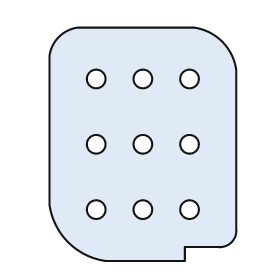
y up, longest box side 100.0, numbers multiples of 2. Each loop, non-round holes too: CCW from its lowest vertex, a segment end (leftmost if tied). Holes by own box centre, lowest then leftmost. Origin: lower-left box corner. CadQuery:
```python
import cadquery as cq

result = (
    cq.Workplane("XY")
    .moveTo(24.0, 0.0)
    .lineTo(58.0, 0.0)
    .lineTo(58.0, 6.0)
    .lineTo(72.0, 6.0)
    .threePointArc((78.0, 8.0), (80.0, 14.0))
    .lineTo(80.0, 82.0)
    .threePointArc((74.0, 94.0), (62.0, 100.0))
    .lineTo(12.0, 100.0)
    .threePointArc((4.0, 96.0), (0.0, 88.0))
    .lineTo(0.0, 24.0)
    .threePointArc((8.0, 8.0), (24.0, 0.0))
    .close()
    .moveTo(20.0, 22.0)
    .circle(4.0)
    .moveTo(40.0, 22.0)
    .circle(4.0)
    .moveTo(60.0, 22.0)
    .circle(4.0)
    .moveTo(20.0, 50.0)
    .circle(4.0)
    .moveTo(40.0, 50.0)
    .circle(4.0)
    .moveTo(60.0, 50.0)
    .circle(4.0)
    .moveTo(20.0, 78.0)
    .circle(4.0)
    .moveTo(40.0, 78.0)
    .circle(4.0)
    .moveTo(60.0, 78.0)
    .circle(4.0)
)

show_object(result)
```